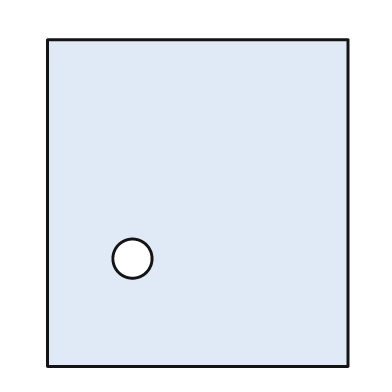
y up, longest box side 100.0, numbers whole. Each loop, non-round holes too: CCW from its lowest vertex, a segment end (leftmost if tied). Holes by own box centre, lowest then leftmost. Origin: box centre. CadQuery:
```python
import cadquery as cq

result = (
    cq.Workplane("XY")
    .moveTo(-46.0, -50.0)
    .lineTo(46.0, -50.0)
    .lineTo(46.0, 50.0)
    .lineTo(-46.0, 50.0)
    .close()
    .moveTo(-20.0, -17.0)
    .circle(6.0)
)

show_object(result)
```